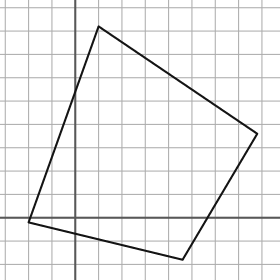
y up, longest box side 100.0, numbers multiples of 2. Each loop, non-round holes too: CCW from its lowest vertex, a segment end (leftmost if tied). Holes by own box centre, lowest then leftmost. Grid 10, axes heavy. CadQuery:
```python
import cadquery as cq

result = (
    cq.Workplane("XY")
    .moveTo(46.0, -18.0)
    .lineTo(78.0, 36.0)
    .lineTo(10.0, 82.0)
    .lineTo(-20.0, -2.0)
    .close()
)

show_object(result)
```